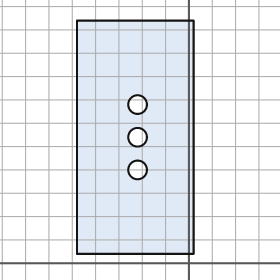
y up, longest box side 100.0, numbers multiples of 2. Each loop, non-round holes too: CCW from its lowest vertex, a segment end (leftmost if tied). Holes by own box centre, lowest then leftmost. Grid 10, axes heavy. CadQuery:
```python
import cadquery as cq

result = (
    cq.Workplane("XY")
    .moveTo(-48.0, 4.0)
    .lineTo(2.0, 4.0)
    .lineTo(2.0, 104.0)
    .lineTo(-48.0, 104.0)
    .close()
    .moveTo(-22.0, 40.0)
    .circle(4.0)
    .moveTo(-22.0, 54.0)
    .circle(4.0)
    .moveTo(-22.0, 68.0)
    .circle(4.0)
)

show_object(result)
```